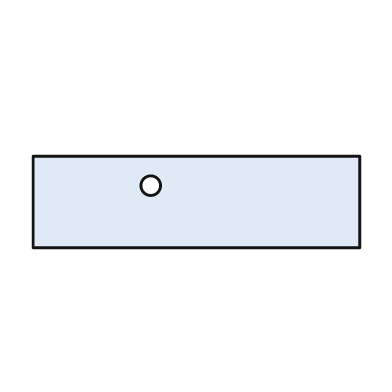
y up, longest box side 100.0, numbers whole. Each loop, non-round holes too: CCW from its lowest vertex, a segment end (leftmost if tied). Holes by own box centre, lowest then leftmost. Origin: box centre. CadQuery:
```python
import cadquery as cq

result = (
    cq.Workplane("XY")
    .moveTo(-50.0, -14.0)
    .lineTo(50.0, -14.0)
    .lineTo(50.0, 14.0)
    .lineTo(-50.0, 14.0)
    .close()
    .moveTo(-14.0, 5.0)
    .circle(3.0)
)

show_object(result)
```